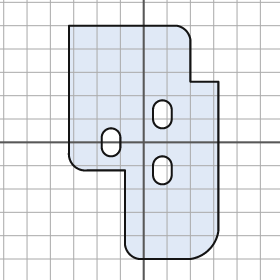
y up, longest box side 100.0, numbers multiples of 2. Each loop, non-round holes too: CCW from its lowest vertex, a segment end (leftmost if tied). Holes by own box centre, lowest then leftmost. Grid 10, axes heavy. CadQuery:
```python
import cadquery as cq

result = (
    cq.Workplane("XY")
    .moveTo(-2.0, -50.0)
    .lineTo(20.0, -50.0)
    .threePointArc((28.0, -46.0), (32.0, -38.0))
    .lineTo(32.0, 26.0)
    .lineTo(20.0, 26.0)
    .lineTo(20.0, 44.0)
    .threePointArc((18.0, 48.0), (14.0, 50.0))
    .lineTo(-32.0, 50.0)
    .lineTo(-32.0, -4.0)
    .threePointArc((-30.0, -10.0), (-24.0, -12.0))
    .lineTo(-8.0, -12.0)
    .lineTo(-8.0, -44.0)
    .threePointArc((-6.0, -48.0), (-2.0, -50.0))
    .close()
    .moveTo(4.0, -14.0)
    .threePointArc((8.0, -18.0), (12.0, -14.0))
    .lineTo(12.0, -10.0)
    .threePointArc((8.0, -6.0), (4.0, -10.0))
    .close()
    .moveTo(-18.0, -2.0)
    .threePointArc((-14.0, -6.0), (-10.0, -2.0))
    .lineTo(-10.0, 2.0)
    .threePointArc((-14.0, 6.0), (-18.0, 2.0))
    .close()
    .moveTo(4.0, 10.0)
    .threePointArc((8.0, 6.0), (12.0, 10.0))
    .lineTo(12.0, 14.0)
    .threePointArc((8.0, 18.0), (4.0, 14.0))
    .close()
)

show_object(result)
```